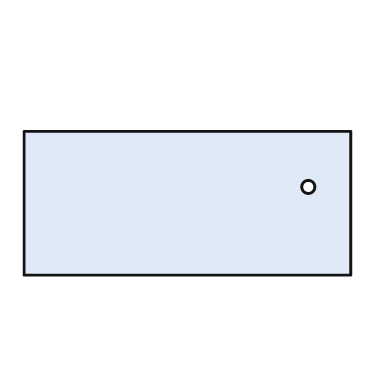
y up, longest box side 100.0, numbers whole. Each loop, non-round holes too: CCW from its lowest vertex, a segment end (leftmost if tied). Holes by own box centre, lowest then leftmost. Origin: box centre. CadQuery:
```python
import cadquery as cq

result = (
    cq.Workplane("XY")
    .moveTo(-50.0, -22.0)
    .lineTo(50.0, -22.0)
    .lineTo(50.0, 22.0)
    .lineTo(-50.0, 22.0)
    .close()
    .moveTo(37.0, 5.0)
    .circle(2.0)
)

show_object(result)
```